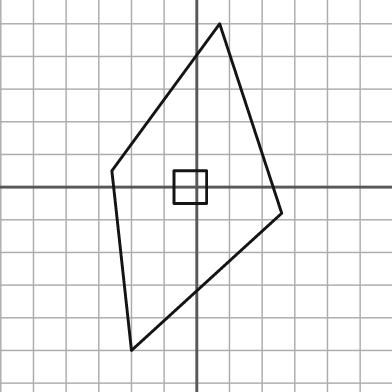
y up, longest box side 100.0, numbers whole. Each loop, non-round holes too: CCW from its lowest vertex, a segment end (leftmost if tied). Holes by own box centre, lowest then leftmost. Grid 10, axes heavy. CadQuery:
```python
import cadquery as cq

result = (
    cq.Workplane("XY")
    .moveTo(-20.0, -50.0)
    .lineTo(26.0, -8.0)
    .lineTo(7.0, 50.0)
    .lineTo(-26.0, 5.0)
    .close()
    .moveTo(-7.0, -5.0)
    .lineTo(3.0, -5.0)
    .lineTo(3.0, 5.0)
    .lineTo(-7.0, 5.0)
    .close()
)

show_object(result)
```